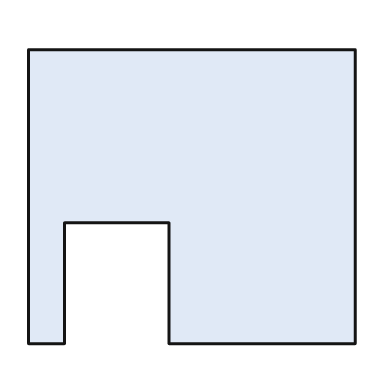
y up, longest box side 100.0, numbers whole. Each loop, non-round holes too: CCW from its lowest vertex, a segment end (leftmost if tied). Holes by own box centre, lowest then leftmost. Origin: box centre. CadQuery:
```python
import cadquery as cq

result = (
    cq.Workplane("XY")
    .moveTo(-50.0, -45.0)
    .lineTo(-39.0, -45.0)
    .lineTo(-39.0, -8.0)
    .lineTo(-7.0, -8.0)
    .lineTo(-7.0, -45.0)
    .lineTo(50.0, -45.0)
    .lineTo(50.0, 45.0)
    .lineTo(-50.0, 45.0)
    .close()
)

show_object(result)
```